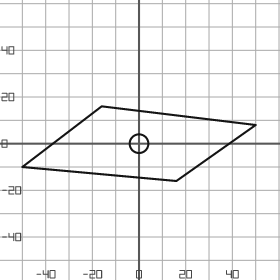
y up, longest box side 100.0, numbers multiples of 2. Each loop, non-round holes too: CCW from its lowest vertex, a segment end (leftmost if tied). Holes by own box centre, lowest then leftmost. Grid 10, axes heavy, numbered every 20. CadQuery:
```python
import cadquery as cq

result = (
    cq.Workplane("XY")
    .moveTo(16.0, -16.0)
    .lineTo(50.0, 8.0)
    .lineTo(-16.0, 16.0)
    .lineTo(-50.0, -10.0)
    .close()
    .moveTo(0.0, 0.0)
    .circle(4.0)
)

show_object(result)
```